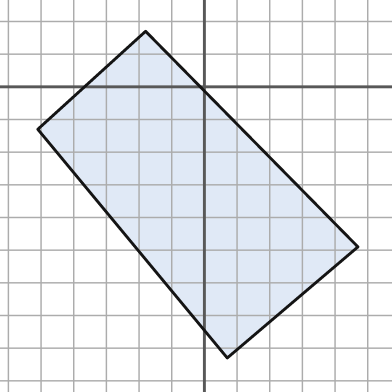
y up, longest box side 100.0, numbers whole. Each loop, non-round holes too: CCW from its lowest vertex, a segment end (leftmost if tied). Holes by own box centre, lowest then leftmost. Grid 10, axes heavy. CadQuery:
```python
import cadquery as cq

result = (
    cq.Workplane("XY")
    .moveTo(7.0, -83.0)
    .lineTo(47.0, -49.0)
    .lineTo(-18.0, 17.0)
    .lineTo(-51.0, -13.0)
    .close()
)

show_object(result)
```